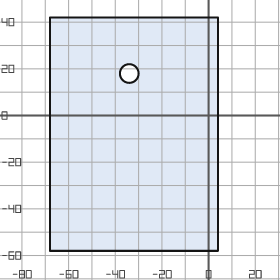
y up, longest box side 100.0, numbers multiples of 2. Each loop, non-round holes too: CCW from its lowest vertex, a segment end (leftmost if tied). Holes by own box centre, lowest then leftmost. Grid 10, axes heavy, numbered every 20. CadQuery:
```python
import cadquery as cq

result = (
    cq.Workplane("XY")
    .moveTo(-68.0, -58.0)
    .lineTo(4.0, -58.0)
    .lineTo(4.0, 42.0)
    .lineTo(-68.0, 42.0)
    .close()
    .moveTo(-34.0, 18.0)
    .circle(4.0)
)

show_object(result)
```